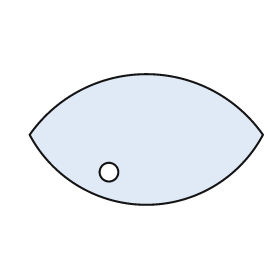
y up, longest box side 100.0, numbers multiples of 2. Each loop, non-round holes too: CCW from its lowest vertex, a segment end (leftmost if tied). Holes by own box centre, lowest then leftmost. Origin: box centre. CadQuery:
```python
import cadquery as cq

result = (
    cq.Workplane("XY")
    .moveTo(-50.0, 2.0)
    .threePointArc((0.0, -28.0), (50.0, 2.0))
    .threePointArc((0.0, 28.0), (-50.0, 2.0))
    .close()
    .moveTo(-16.0, -14.0)
    .circle(4.0)
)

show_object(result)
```